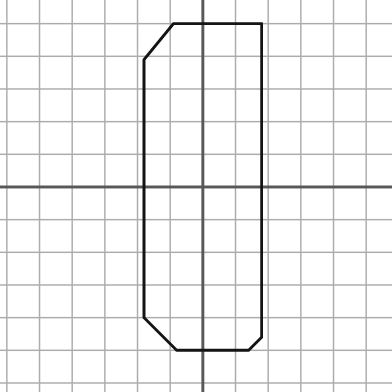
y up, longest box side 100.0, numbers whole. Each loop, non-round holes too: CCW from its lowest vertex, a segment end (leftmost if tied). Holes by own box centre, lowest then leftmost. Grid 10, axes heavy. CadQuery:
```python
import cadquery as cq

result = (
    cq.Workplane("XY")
    .moveTo(-8.0, -50.0)
    .lineTo(14.0, -50.0)
    .lineTo(18.0, -46.0)
    .lineTo(18.0, 50.0)
    .lineTo(-9.0, 50.0)
    .lineTo(-18.0, 39.0)
    .lineTo(-18.0, -40.0)
    .close()
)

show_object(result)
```